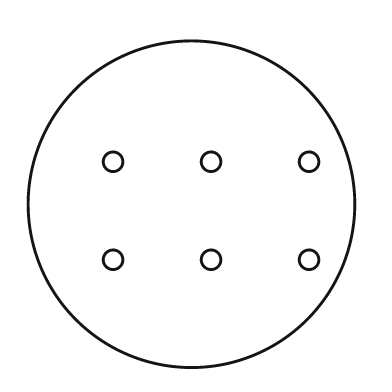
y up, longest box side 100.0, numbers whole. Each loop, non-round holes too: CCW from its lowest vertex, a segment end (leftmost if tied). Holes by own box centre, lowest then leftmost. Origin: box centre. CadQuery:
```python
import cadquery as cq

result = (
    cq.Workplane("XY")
    .moveTo(0.0, 0.0)
    .circle(50.0)
    .moveTo(-24.0, -17.0)
    .circle(3.0)
    .moveTo(6.0, -17.0)
    .circle(3.0)
    .moveTo(36.0, -17.0)
    .circle(3.0)
    .moveTo(-24.0, 13.0)
    .circle(3.0)
    .moveTo(6.0, 13.0)
    .circle(3.0)
    .moveTo(36.0, 13.0)
    .circle(3.0)
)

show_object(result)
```